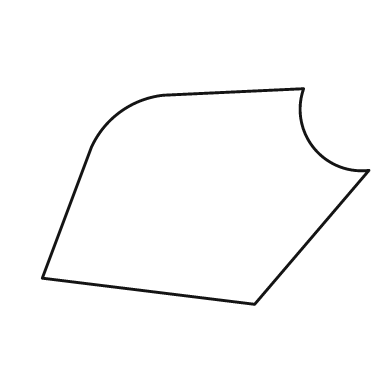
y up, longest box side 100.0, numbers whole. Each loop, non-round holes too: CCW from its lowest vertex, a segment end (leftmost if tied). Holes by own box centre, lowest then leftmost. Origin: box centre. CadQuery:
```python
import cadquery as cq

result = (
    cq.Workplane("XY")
    .moveTo(15.0, -33.0)
    .lineTo(50.0, 8.0)
    .threePointArc((33.0, 15.0), (30.0, 33.0))
    .lineTo(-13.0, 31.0)
    .threePointArc((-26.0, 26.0), (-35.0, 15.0))
    .lineTo(-50.0, -25.0)
    .close()
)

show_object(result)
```